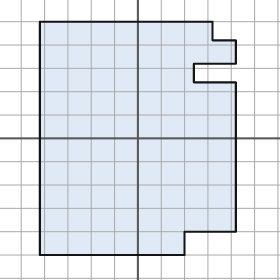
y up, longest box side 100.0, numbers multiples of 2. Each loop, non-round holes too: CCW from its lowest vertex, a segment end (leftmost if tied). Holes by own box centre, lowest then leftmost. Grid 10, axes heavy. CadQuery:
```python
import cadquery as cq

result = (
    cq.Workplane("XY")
    .moveTo(-42.0, -50.0)
    .lineTo(20.0, -50.0)
    .lineTo(20.0, -40.0)
    .lineTo(42.0, -40.0)
    .lineTo(42.0, 24.0)
    .lineTo(24.0, 24.0)
    .lineTo(24.0, 32.0)
    .lineTo(42.0, 32.0)
    .lineTo(42.0, 42.0)
    .lineTo(32.0, 42.0)
    .lineTo(32.0, 50.0)
    .lineTo(-42.0, 50.0)
    .close()
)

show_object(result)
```